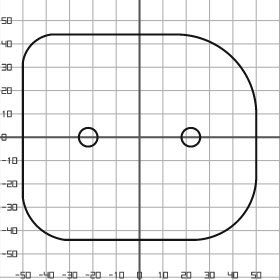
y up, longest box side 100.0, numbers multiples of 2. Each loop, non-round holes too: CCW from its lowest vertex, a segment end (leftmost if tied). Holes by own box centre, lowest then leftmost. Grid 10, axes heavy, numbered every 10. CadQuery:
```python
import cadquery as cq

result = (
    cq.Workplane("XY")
    .moveTo(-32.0, -44.0)
    .lineTo(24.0, -44.0)
    .threePointArc((42.0, -36.0), (50.0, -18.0))
    .lineTo(50.0, 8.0)
    .threePointArc((40.0, 34.0), (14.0, 44.0))
    .lineTo(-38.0, 44.0)
    .threePointArc((-46.0, 40.0), (-50.0, 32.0))
    .lineTo(-50.0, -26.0)
    .threePointArc((-44.0, -38.0), (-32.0, -44.0))
    .close()
    .moveTo(-22.0, 0.0)
    .circle(4.0)
    .moveTo(22.0, 0.0)
    .circle(4.0)
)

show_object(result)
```